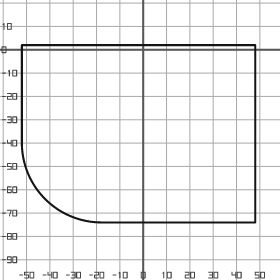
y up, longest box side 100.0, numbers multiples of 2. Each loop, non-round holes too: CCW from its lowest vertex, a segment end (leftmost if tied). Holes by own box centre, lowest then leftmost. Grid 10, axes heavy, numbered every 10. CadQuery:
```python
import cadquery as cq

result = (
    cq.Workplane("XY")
    .moveTo(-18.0, -74.0)
    .lineTo(48.0, -74.0)
    .lineTo(48.0, 2.0)
    .lineTo(-52.0, 2.0)
    .lineTo(-52.0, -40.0)
    .threePointArc((-42.0, -64.0), (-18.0, -74.0))
    .close()
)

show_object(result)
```